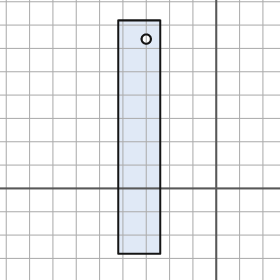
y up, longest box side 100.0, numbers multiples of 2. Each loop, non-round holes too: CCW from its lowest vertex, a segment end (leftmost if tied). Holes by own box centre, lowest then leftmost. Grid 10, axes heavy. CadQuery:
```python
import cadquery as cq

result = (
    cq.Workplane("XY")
    .moveTo(-42.0, -28.0)
    .lineTo(-24.0, -28.0)
    .lineTo(-24.0, 72.0)
    .lineTo(-42.0, 72.0)
    .close()
    .moveTo(-30.0, 64.0)
    .circle(2.0)
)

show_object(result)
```